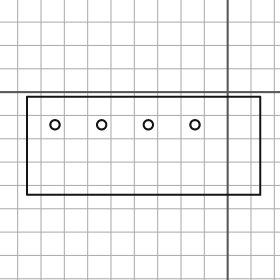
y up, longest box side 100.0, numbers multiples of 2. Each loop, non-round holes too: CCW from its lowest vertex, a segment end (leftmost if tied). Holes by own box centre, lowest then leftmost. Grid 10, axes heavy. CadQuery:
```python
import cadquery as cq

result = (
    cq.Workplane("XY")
    .moveTo(-86.0, -44.0)
    .lineTo(14.0, -44.0)
    .lineTo(14.0, -2.0)
    .lineTo(-86.0, -2.0)
    .close()
    .moveTo(-74.0, -14.0)
    .circle(2.0)
    .moveTo(-54.0, -14.0)
    .circle(2.0)
    .moveTo(-34.0, -14.0)
    .circle(2.0)
    .moveTo(-14.0, -14.0)
    .circle(2.0)
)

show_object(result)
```